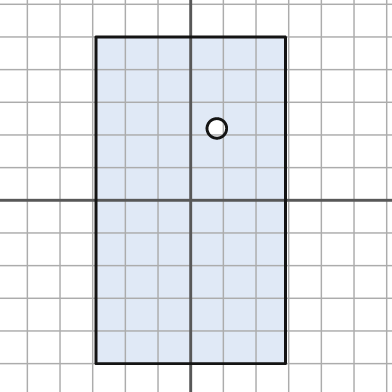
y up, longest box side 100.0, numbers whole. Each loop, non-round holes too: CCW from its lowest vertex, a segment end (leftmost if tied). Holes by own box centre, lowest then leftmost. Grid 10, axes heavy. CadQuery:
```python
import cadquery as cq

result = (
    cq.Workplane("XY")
    .moveTo(-29.0, -50.0)
    .lineTo(29.0, -50.0)
    .lineTo(29.0, 50.0)
    .lineTo(-29.0, 50.0)
    .close()
    .moveTo(8.0, 22.0)
    .circle(3.0)
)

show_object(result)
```